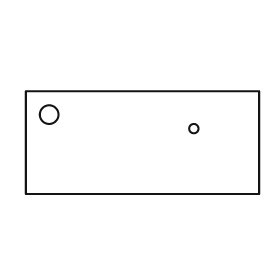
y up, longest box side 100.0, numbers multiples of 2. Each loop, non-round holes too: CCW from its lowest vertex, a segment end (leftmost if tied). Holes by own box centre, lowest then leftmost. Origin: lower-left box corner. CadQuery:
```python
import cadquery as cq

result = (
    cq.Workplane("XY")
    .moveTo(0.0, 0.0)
    .lineTo(100.0, 0.0)
    .lineTo(100.0, 44.0)
    .lineTo(0.0, 44.0)
    .close()
    .moveTo(72.0, 28.0)
    .circle(2.0)
    .moveTo(10.0, 34.0)
    .circle(4.0)
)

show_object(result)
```